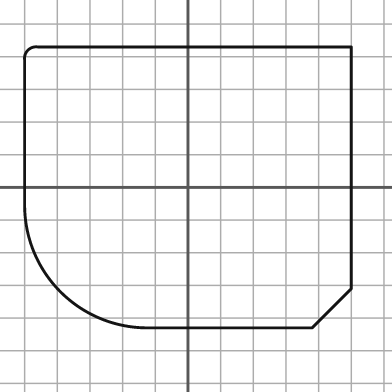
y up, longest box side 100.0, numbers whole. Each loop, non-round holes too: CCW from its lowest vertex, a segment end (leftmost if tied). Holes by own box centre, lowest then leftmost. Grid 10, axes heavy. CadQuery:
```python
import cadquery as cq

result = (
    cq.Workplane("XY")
    .moveTo(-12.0, -43.0)
    .lineTo(38.0, -43.0)
    .lineTo(50.0, -31.0)
    .lineTo(50.0, 43.0)
    .lineTo(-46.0, 43.0)
    .threePointArc((-49.0, 42.0), (-50.0, 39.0))
    .lineTo(-50.0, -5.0)
    .threePointArc((-39.0, -32.0), (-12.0, -43.0))
    .close()
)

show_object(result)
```